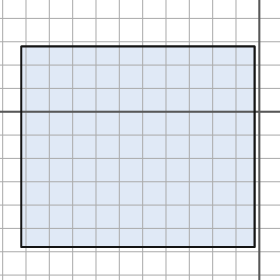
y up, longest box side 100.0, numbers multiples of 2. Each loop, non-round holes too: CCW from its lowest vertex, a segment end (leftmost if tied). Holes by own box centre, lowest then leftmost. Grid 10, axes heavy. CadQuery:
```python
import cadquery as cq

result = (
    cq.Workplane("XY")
    .moveTo(-102.0, -58.0)
    .lineTo(-2.0, -58.0)
    .lineTo(-2.0, 28.0)
    .lineTo(-102.0, 28.0)
    .close()
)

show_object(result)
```